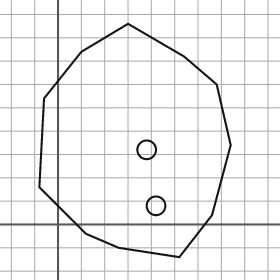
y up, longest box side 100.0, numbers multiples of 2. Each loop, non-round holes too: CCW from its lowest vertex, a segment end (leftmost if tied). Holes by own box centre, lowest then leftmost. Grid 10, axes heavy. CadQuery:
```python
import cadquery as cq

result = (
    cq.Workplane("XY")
    .moveTo(52.0, -14.0)
    .lineTo(66.0, 4.0)
    .lineTo(74.0, 34.0)
    .lineTo(68.0, 60.0)
    .lineTo(54.0, 72.0)
    .lineTo(30.0, 86.0)
    .lineTo(10.0, 74.0)
    .lineTo(-6.0, 54.0)
    .lineTo(-8.0, 16.0)
    .lineTo(12.0, -4.0)
    .lineTo(26.0, -10.0)
    .close()
    .moveTo(42.0, 8.0)
    .circle(4.0)
    .moveTo(38.0, 32.0)
    .circle(4.0)
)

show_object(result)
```